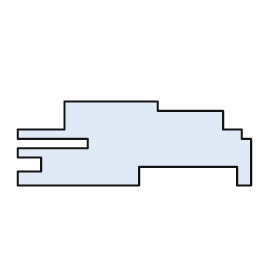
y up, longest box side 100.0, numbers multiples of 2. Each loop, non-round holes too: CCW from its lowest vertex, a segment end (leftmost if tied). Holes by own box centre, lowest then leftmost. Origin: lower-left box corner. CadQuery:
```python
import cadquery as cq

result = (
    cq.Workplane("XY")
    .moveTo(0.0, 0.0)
    .lineTo(52.0, 0.0)
    .lineTo(52.0, 8.0)
    .lineTo(94.0, 8.0)
    .lineTo(94.0, 0.0)
    .lineTo(100.0, 0.0)
    .lineTo(100.0, 20.0)
    .lineTo(96.0, 20.0)
    .lineTo(96.0, 24.0)
    .lineTo(88.0, 24.0)
    .lineTo(88.0, 32.0)
    .lineTo(60.0, 32.0)
    .lineTo(60.0, 36.0)
    .lineTo(20.0, 36.0)
    .lineTo(20.0, 24.0)
    .lineTo(0.0, 24.0)
    .lineTo(0.0, 20.0)
    .lineTo(30.0, 20.0)
    .lineTo(30.0, 16.0)
    .lineTo(0.0, 16.0)
    .lineTo(0.0, 12.0)
    .lineTo(10.0, 12.0)
    .lineTo(10.0, 6.0)
    .lineTo(0.0, 6.0)
    .close()
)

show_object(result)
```